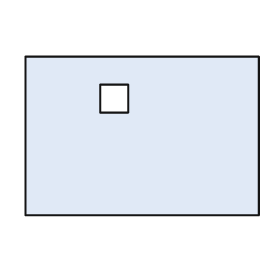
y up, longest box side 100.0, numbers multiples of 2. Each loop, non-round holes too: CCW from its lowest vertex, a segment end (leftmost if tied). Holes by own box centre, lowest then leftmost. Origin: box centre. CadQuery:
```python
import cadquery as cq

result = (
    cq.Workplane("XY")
    .moveTo(-50.0, -34.0)
    .lineTo(50.0, -34.0)
    .lineTo(50.0, 34.0)
    .lineTo(-50.0, 34.0)
    .close()
    .moveTo(-18.0, 10.0)
    .lineTo(-6.0, 10.0)
    .lineTo(-6.0, 22.0)
    .lineTo(-18.0, 22.0)
    .close()
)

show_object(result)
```